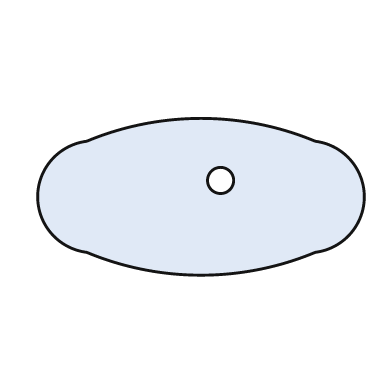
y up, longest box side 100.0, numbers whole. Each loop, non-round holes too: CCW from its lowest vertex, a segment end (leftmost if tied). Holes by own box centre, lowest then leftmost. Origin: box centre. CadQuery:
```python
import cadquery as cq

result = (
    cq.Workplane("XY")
    .moveTo(-35.0, -17.0)
    .threePointArc((0.0, -24.0), (35.0, -17.0))
    .threePointArc((50.0, 0.0), (35.0, 17.0))
    .threePointArc((0.0, 24.0), (-35.0, 17.0))
    .threePointArc((-50.0, 0.0), (-35.0, -17.0))
    .close()
    .moveTo(6.0, 5.0)
    .circle(4.0)
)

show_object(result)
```